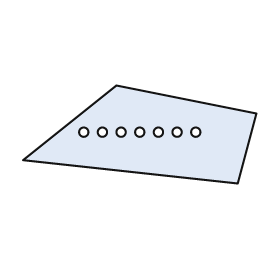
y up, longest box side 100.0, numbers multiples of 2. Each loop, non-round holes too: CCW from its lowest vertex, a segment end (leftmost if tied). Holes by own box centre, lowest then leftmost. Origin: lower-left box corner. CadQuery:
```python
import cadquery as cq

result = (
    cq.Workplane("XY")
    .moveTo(92.0, 0.0)
    .lineTo(100.0, 30.0)
    .lineTo(40.0, 42.0)
    .lineTo(0.0, 10.0)
    .close()
    .moveTo(26.0, 22.0)
    .circle(2.0)
    .moveTo(34.0, 22.0)
    .circle(2.0)
    .moveTo(42.0, 22.0)
    .circle(2.0)
    .moveTo(50.0, 22.0)
    .circle(2.0)
    .moveTo(58.0, 22.0)
    .circle(2.0)
    .moveTo(66.0, 22.0)
    .circle(2.0)
    .moveTo(74.0, 22.0)
    .circle(2.0)
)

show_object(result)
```